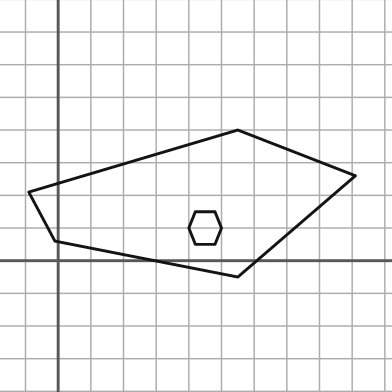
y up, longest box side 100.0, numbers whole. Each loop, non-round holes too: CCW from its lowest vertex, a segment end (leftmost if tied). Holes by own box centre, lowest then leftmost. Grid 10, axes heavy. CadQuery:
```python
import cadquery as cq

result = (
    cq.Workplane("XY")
    .moveTo(55.0, -5.0)
    .lineTo(91.0, 26.0)
    .lineTo(55.0, 40.0)
    .lineTo(-9.0, 21.0)
    .lineTo(-1.0, 6.0)
    .close()
    .moveTo(42.0, 5.0)
    .lineTo(48.0, 5.0)
    .lineTo(50.0, 10.0)
    .lineTo(48.0, 15.0)
    .lineTo(42.0, 15.0)
    .lineTo(40.0, 10.0)
    .close()
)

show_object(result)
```